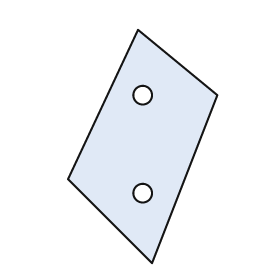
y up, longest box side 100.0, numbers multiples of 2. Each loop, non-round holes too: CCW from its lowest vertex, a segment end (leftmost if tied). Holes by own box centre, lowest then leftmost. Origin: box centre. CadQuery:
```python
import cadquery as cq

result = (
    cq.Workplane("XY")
    .moveTo(4.0, -50.0)
    .lineTo(32.0, 22.0)
    .lineTo(-2.0, 50.0)
    .lineTo(-32.0, -14.0)
    .close()
    .moveTo(0.0, -20.0)
    .circle(4.0)
    .moveTo(0.0, 22.0)
    .circle(4.0)
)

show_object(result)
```